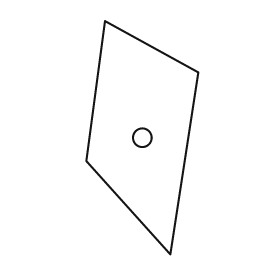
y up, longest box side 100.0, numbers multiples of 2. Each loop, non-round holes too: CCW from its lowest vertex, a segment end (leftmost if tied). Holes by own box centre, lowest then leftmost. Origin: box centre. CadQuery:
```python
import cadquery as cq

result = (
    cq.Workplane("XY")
    .moveTo(12.0, -50.0)
    .lineTo(24.0, 28.0)
    .lineTo(-16.0, 50.0)
    .lineTo(-24.0, -10.0)
    .close()
    .moveTo(0.0, 0.0)
    .circle(4.0)
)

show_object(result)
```